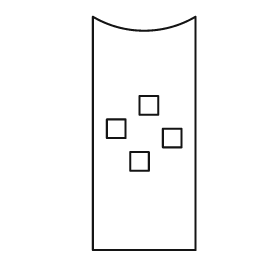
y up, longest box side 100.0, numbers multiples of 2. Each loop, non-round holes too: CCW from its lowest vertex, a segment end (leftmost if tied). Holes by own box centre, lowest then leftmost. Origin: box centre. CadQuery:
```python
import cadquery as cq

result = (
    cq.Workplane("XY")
    .moveTo(-22.0, -50.0)
    .lineTo(22.0, -50.0)
    .lineTo(22.0, 50.0)
    .threePointArc((0.0, 44.0), (-22.0, 50.0))
    .close()
    .moveTo(-6.0, -16.0)
    .lineTo(2.0, -16.0)
    .lineTo(2.0, -8.0)
    .lineTo(-6.0, -8.0)
    .close()
    .moveTo(8.0, -6.0)
    .lineTo(16.0, -6.0)
    .lineTo(16.0, 2.0)
    .lineTo(8.0, 2.0)
    .close()
    .moveTo(-16.0, -2.0)
    .lineTo(-8.0, -2.0)
    .lineTo(-8.0, 6.0)
    .lineTo(-16.0, 6.0)
    .close()
    .moveTo(-2.0, 8.0)
    .lineTo(6.0, 8.0)
    .lineTo(6.0, 16.0)
    .lineTo(-2.0, 16.0)
    .close()
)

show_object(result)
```